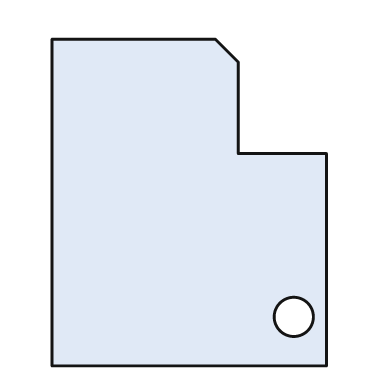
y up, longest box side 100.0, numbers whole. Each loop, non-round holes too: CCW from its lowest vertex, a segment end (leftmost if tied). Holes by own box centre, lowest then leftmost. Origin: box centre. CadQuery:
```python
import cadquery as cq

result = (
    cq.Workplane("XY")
    .moveTo(-42.0, -50.0)
    .lineTo(42.0, -50.0)
    .lineTo(42.0, 15.0)
    .lineTo(15.0, 15.0)
    .lineTo(15.0, 43.0)
    .lineTo(8.0, 50.0)
    .lineTo(-42.0, 50.0)
    .close()
    .moveTo(32.0, -35.0)
    .circle(6.0)
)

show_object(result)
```